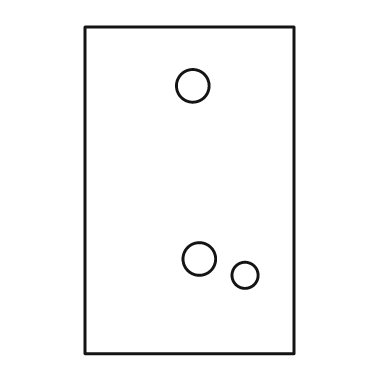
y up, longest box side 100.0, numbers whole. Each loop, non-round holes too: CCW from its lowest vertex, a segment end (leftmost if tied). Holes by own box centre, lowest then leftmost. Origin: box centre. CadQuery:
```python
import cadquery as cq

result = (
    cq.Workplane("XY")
    .moveTo(-32.0, -50.0)
    .lineTo(32.0, -50.0)
    .lineTo(32.0, 50.0)
    .lineTo(-32.0, 50.0)
    .close()
    .moveTo(17.0, -26.0)
    .circle(4.0)
    .moveTo(3.0, -21.0)
    .circle(5.0)
    .moveTo(1.0, 32.0)
    .circle(5.0)
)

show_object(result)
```